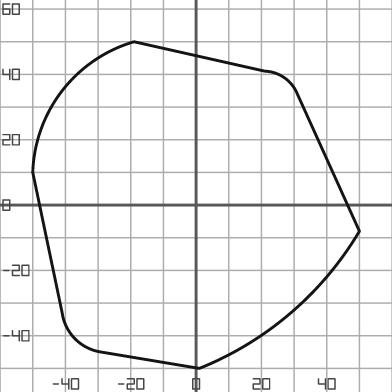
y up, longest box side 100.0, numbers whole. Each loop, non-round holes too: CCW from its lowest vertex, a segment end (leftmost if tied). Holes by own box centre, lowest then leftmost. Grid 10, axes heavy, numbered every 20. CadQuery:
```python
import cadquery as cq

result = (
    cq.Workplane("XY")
    .moveTo(1.0, -50.0)
    .threePointArc((29.0, -33.0), (50.0, -8.0))
    .lineTo(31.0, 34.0)
    .threePointArc((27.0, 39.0), (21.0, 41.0))
    .lineTo(-19.0, 50.0)
    .threePointArc((-41.0, 35.0), (-50.0, 10.0))
    .lineTo(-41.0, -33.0)
    .threePointArc((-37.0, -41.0), (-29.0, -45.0))
    .close()
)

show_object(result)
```